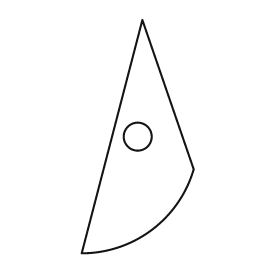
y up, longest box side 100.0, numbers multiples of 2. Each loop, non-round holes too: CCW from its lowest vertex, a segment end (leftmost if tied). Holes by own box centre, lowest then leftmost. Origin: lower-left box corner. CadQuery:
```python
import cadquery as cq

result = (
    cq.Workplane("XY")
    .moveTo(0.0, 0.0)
    .threePointArc((30.0, 10.0), (48.0, 36.0))
    .lineTo(26.0, 100.0)
    .close()
    .moveTo(24.0, 50.0)
    .circle(6.0)
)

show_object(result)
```